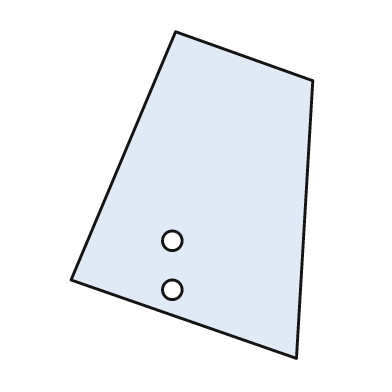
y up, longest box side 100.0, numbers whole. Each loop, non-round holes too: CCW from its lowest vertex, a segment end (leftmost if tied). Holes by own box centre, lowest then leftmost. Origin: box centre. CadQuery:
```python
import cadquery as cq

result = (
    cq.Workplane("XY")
    .moveTo(32.0, -50.0)
    .lineTo(37.0, 35.0)
    .lineTo(-5.0, 50.0)
    .lineTo(-37.0, -26.0)
    .close()
    .moveTo(-6.0, -29.0)
    .circle(3.0)
    .moveTo(-6.0, -14.0)
    .circle(3.0)
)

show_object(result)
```